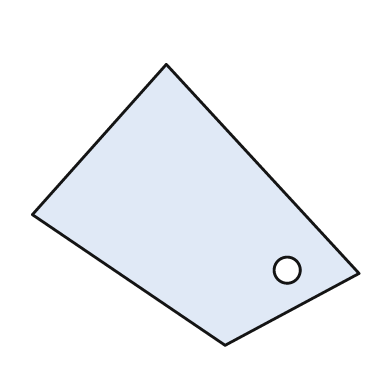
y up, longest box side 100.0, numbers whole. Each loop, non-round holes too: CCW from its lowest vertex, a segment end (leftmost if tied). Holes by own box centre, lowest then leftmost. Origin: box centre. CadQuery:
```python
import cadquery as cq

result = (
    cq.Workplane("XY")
    .moveTo(9.0, -43.0)
    .lineTo(50.0, -21.0)
    .lineTo(-9.0, 43.0)
    .lineTo(-50.0, -3.0)
    .close()
    .moveTo(28.0, -20.0)
    .circle(4.0)
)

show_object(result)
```